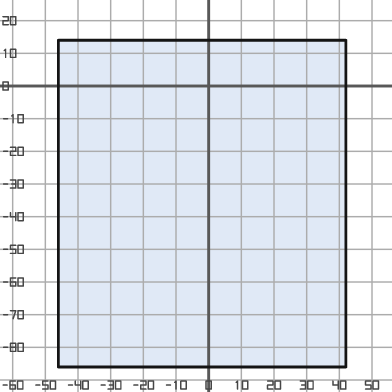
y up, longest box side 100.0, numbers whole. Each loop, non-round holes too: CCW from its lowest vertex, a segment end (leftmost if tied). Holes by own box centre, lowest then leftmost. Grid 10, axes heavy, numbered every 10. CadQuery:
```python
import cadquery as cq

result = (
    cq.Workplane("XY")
    .moveTo(-46.0, -86.0)
    .lineTo(42.0, -86.0)
    .lineTo(42.0, 14.0)
    .lineTo(-46.0, 14.0)
    .close()
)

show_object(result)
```